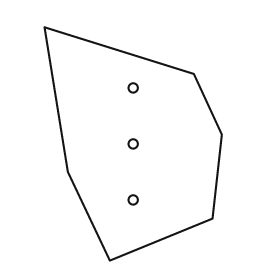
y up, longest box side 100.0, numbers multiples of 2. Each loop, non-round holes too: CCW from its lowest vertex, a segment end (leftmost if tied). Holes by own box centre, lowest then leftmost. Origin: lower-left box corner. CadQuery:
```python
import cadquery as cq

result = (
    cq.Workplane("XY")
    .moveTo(28.0, 0.0)
    .lineTo(72.0, 18.0)
    .lineTo(76.0, 54.0)
    .lineTo(64.0, 80.0)
    .lineTo(0.0, 100.0)
    .lineTo(10.0, 38.0)
    .close()
    .moveTo(38.0, 26.0)
    .circle(2.0)
    .moveTo(38.0, 50.0)
    .circle(2.0)
    .moveTo(38.0, 74.0)
    .circle(2.0)
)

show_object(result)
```